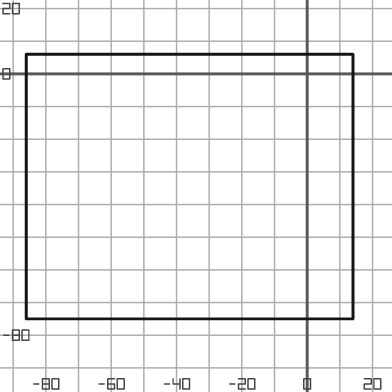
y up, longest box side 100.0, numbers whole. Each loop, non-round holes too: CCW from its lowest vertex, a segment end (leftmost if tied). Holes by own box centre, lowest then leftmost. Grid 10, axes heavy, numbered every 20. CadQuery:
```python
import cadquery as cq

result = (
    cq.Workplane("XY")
    .moveTo(-86.0, -75.0)
    .lineTo(14.0, -75.0)
    .lineTo(14.0, 6.0)
    .lineTo(-86.0, 6.0)
    .close()
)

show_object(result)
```